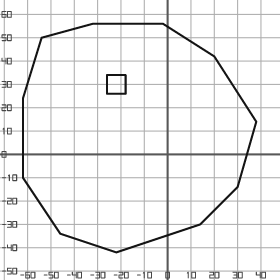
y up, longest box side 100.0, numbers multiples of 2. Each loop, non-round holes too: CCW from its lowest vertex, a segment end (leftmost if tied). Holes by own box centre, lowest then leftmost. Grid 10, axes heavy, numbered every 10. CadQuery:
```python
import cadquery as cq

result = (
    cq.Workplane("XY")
    .moveTo(-22.0, -42.0)
    .lineTo(14.0, -30.0)
    .lineTo(30.0, -14.0)
    .lineTo(38.0, 14.0)
    .lineTo(20.0, 42.0)
    .lineTo(-2.0, 56.0)
    .lineTo(-32.0, 56.0)
    .lineTo(-54.0, 50.0)
    .lineTo(-62.0, 24.0)
    .lineTo(-62.0, -10.0)
    .lineTo(-46.0, -34.0)
    .close()
    .moveTo(-26.0, 26.0)
    .lineTo(-18.0, 26.0)
    .lineTo(-18.0, 34.0)
    .lineTo(-26.0, 34.0)
    .close()
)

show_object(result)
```